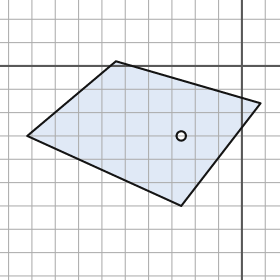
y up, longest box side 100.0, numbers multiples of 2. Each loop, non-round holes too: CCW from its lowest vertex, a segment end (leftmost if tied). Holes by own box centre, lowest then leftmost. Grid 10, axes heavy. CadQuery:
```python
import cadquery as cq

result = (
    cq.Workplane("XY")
    .moveTo(-26.0, -60.0)
    .lineTo(8.0, -16.0)
    .lineTo(-54.0, 2.0)
    .lineTo(-92.0, -30.0)
    .close()
    .moveTo(-26.0, -30.0)
    .circle(2.0)
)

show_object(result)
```